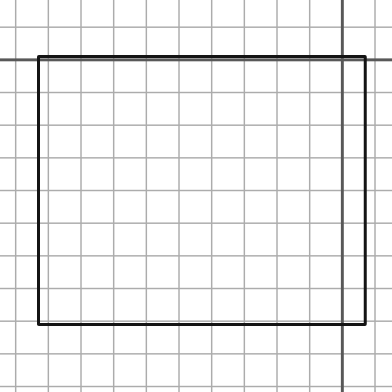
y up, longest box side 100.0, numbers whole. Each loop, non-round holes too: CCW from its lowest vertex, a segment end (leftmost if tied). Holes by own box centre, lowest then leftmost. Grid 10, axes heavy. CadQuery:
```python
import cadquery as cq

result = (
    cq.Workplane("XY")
    .moveTo(-93.0, -81.0)
    .lineTo(7.0, -81.0)
    .lineTo(7.0, 1.0)
    .lineTo(-93.0, 1.0)
    .close()
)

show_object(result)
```